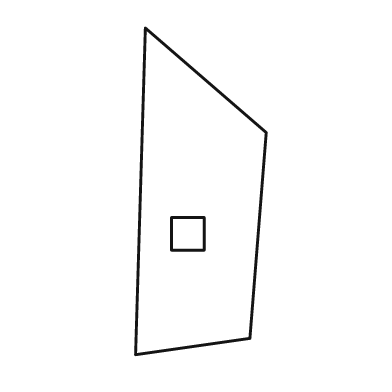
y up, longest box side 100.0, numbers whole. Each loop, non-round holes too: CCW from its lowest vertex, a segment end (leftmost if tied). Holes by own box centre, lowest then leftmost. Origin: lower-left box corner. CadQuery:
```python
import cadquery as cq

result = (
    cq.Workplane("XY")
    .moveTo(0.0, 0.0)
    .lineTo(35.0, 5.0)
    .lineTo(40.0, 68.0)
    .lineTo(3.0, 100.0)
    .close()
    .moveTo(11.0, 32.0)
    .lineTo(21.0, 32.0)
    .lineTo(21.0, 42.0)
    .lineTo(11.0, 42.0)
    .close()
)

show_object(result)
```